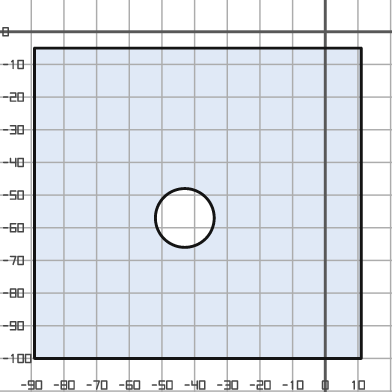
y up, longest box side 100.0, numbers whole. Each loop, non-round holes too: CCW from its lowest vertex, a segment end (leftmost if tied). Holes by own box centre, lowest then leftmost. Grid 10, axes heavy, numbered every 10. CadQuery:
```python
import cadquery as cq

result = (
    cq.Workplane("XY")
    .moveTo(-89.0, -100.0)
    .lineTo(11.0, -100.0)
    .lineTo(11.0, -5.0)
    .lineTo(-89.0, -5.0)
    .close()
    .moveTo(-43.0, -57.0)
    .circle(9.0)
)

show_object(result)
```